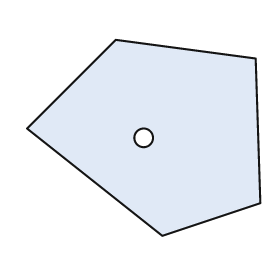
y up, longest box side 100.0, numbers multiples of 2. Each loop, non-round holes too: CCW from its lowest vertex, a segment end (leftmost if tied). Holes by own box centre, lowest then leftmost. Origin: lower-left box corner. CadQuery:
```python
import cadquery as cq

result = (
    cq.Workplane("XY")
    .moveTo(58.0, 0.0)
    .lineTo(100.0, 14.0)
    .lineTo(98.0, 76.0)
    .lineTo(38.0, 84.0)
    .lineTo(0.0, 46.0)
    .close()
    .moveTo(50.0, 42.0)
    .circle(4.0)
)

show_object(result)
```